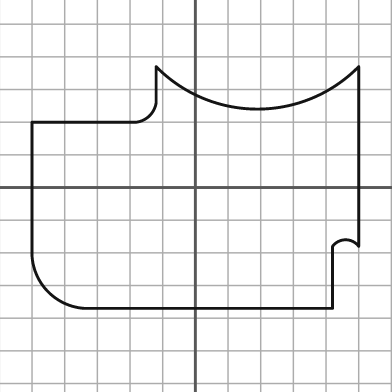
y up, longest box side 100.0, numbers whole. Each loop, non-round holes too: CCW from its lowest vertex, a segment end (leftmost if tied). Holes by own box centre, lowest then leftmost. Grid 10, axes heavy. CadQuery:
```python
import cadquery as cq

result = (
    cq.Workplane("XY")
    .moveTo(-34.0, -37.0)
    .lineTo(42.0, -37.0)
    .lineTo(42.0, -18.0)
    .threePointArc((46.0, -16.0), (50.0, -18.0))
    .lineTo(50.0, 37.0)
    .threePointArc((19.0, 24.0), (-12.0, 37.0))
    .lineTo(-12.0, 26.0)
    .threePointArc((-14.0, 22.0), (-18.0, 20.0))
    .lineTo(-50.0, 20.0)
    .lineTo(-50.0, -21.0)
    .threePointArc((-45.0, -32.0), (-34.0, -37.0))
    .close()
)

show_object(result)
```